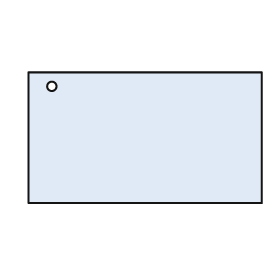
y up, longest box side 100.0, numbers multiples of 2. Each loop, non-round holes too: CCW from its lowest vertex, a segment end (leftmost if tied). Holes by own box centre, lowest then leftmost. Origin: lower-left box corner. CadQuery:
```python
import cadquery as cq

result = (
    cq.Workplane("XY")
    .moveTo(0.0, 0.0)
    .lineTo(100.0, 0.0)
    .lineTo(100.0, 56.0)
    .lineTo(0.0, 56.0)
    .close()
    .moveTo(10.0, 50.0)
    .circle(2.0)
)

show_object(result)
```